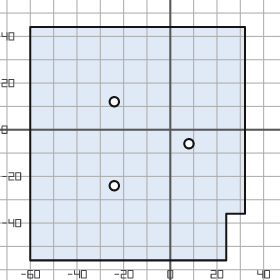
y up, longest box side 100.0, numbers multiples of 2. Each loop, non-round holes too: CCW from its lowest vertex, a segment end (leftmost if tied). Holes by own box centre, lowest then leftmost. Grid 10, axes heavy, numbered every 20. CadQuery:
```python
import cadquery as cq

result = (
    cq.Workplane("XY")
    .moveTo(-60.0, -56.0)
    .lineTo(24.0, -56.0)
    .lineTo(24.0, -36.0)
    .lineTo(32.0, -36.0)
    .lineTo(32.0, 44.0)
    .lineTo(-60.0, 44.0)
    .close()
    .moveTo(-24.0, -24.0)
    .circle(2.0)
    .moveTo(8.0, -6.0)
    .circle(2.0)
    .moveTo(-24.0, 12.0)
    .circle(2.0)
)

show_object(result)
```